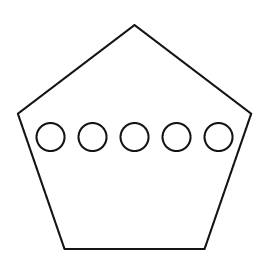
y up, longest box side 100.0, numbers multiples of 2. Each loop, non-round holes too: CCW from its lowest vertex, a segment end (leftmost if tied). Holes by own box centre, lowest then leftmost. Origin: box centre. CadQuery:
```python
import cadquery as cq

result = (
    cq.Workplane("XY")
    .moveTo(-30.0, -48.0)
    .lineTo(30.0, -48.0)
    .lineTo(50.0, 10.0)
    .lineTo(0.0, 48.0)
    .lineTo(-50.0, 10.0)
    .close()
    .moveTo(-36.0, 0.0)
    .circle(6.0)
    .moveTo(-18.0, 0.0)
    .circle(6.0)
    .moveTo(0.0, 0.0)
    .circle(6.0)
    .moveTo(18.0, 0.0)
    .circle(6.0)
    .moveTo(36.0, 0.0)
    .circle(6.0)
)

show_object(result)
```